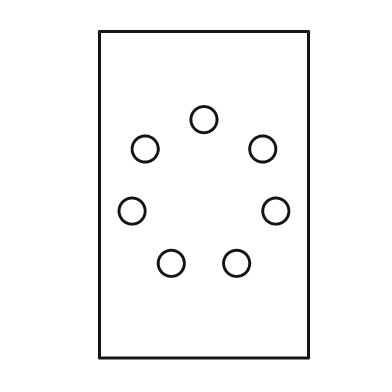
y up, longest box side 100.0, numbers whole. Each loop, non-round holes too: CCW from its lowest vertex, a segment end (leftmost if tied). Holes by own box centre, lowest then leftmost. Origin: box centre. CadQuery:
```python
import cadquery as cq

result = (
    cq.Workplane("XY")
    .moveTo(-32.0, -50.0)
    .lineTo(32.0, -50.0)
    .lineTo(32.0, 50.0)
    .lineTo(-32.0, 50.0)
    .close()
    .moveTo(-10.0, -21.0)
    .circle(4.0)
    .moveTo(10.0, -21.0)
    .circle(4.0)
    .moveTo(-22.0, -5.0)
    .circle(4.0)
    .moveTo(22.0, -5.0)
    .circle(4.0)
    .moveTo(-18.0, 14.0)
    .circle(4.0)
    .moveTo(18.0, 14.0)
    .circle(4.0)
    .moveTo(0.0, 23.0)
    .circle(4.0)
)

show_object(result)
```